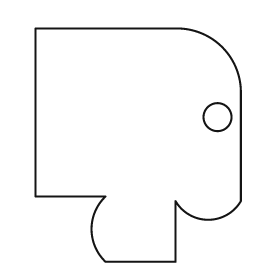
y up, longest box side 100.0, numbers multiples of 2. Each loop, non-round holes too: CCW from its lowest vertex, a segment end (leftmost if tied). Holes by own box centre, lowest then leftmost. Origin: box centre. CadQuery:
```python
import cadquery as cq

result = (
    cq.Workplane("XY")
    .moveTo(-14.0, -50.0)
    .lineTo(16.0, -50.0)
    .lineTo(16.0, -24.0)
    .threePointArc((30.0, -32.0), (44.0, -24.0))
    .lineTo(44.0, 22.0)
    .threePointArc((36.0, 42.0), (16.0, 50.0))
    .lineTo(-44.0, 50.0)
    .lineTo(-44.0, -22.0)
    .lineTo(-14.0, -22.0)
    .threePointArc((-20.0, -36.0), (-14.0, -50.0))
    .close()
    .moveTo(34.0, 12.0)
    .circle(6.0)
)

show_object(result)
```